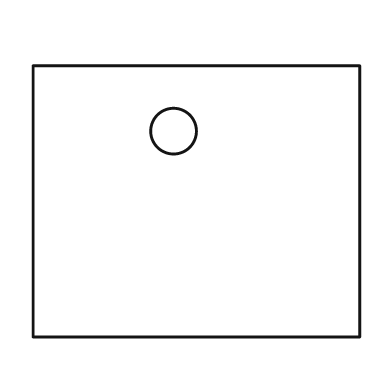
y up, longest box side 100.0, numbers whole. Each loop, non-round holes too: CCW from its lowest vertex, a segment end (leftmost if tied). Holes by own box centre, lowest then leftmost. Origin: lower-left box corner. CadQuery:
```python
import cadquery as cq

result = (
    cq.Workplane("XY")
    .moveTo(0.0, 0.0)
    .lineTo(100.0, 0.0)
    .lineTo(100.0, 83.0)
    .lineTo(0.0, 83.0)
    .close()
    .moveTo(43.0, 63.0)
    .circle(7.0)
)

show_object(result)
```